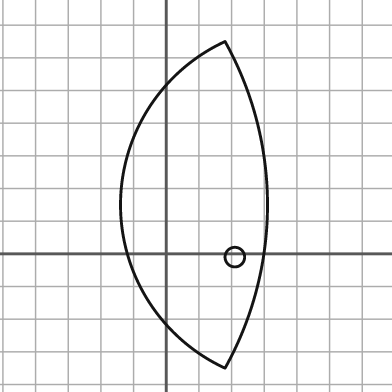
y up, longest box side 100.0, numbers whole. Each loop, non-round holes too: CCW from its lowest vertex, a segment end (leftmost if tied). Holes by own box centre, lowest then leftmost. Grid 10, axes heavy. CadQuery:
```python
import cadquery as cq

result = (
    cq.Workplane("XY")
    .moveTo(18.0, -35.0)
    .threePointArc((31.0, 15.0), (18.0, 65.0))
    .threePointArc((-14.0, 15.0), (18.0, -35.0))
    .close()
    .moveTo(21.0, -1.0)
    .circle(3.0)
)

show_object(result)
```